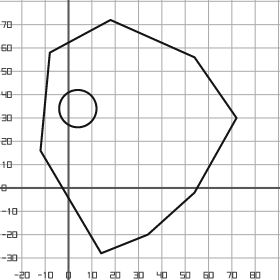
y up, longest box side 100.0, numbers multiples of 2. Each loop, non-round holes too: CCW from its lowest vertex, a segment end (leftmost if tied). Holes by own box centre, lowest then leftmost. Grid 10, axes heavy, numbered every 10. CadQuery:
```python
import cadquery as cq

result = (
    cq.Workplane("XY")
    .moveTo(14.0, -28.0)
    .lineTo(34.0, -20.0)
    .lineTo(54.0, -2.0)
    .lineTo(72.0, 30.0)
    .lineTo(54.0, 56.0)
    .lineTo(18.0, 72.0)
    .lineTo(-8.0, 58.0)
    .lineTo(-12.0, 16.0)
    .close()
    .moveTo(4.0, 34.0)
    .circle(8.0)
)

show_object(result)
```